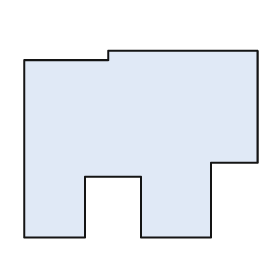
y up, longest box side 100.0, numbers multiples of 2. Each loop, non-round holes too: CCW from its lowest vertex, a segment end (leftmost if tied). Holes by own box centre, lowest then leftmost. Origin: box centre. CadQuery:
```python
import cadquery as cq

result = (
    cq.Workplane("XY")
    .moveTo(-50.0, -40.0)
    .lineTo(-24.0, -40.0)
    .lineTo(-24.0, -14.0)
    .lineTo(0.0, -14.0)
    .lineTo(0.0, -40.0)
    .lineTo(30.0, -40.0)
    .lineTo(30.0, -8.0)
    .lineTo(50.0, -8.0)
    .lineTo(50.0, 40.0)
    .lineTo(-14.0, 40.0)
    .lineTo(-14.0, 36.0)
    .lineTo(-50.0, 36.0)
    .close()
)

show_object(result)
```